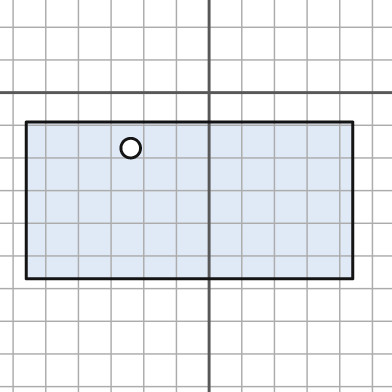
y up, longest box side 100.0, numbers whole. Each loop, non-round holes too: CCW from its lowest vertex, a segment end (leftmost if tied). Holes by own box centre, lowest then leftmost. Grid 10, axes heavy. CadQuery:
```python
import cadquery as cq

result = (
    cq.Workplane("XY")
    .moveTo(-56.0, -57.0)
    .lineTo(44.0, -57.0)
    .lineTo(44.0, -9.0)
    .lineTo(-56.0, -9.0)
    .close()
    .moveTo(-24.0, -17.0)
    .circle(3.0)
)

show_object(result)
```